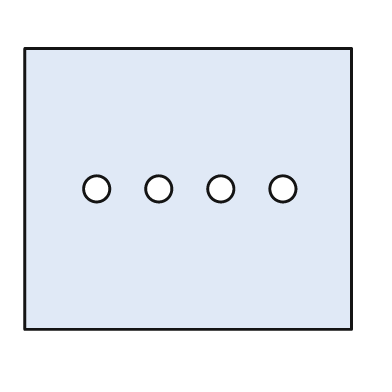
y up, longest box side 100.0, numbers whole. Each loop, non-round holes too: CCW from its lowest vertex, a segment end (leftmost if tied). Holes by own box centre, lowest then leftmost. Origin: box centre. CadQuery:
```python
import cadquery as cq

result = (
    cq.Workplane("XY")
    .moveTo(-50.0, -43.0)
    .lineTo(50.0, -43.0)
    .lineTo(50.0, 43.0)
    .lineTo(-50.0, 43.0)
    .close()
    .moveTo(-28.0, 0.0)
    .circle(4.0)
    .moveTo(-9.0, 0.0)
    .circle(4.0)
    .moveTo(10.0, 0.0)
    .circle(4.0)
    .moveTo(29.0, 0.0)
    .circle(4.0)
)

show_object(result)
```